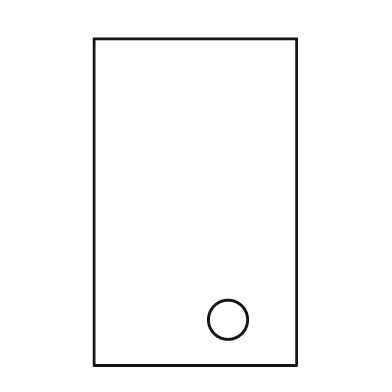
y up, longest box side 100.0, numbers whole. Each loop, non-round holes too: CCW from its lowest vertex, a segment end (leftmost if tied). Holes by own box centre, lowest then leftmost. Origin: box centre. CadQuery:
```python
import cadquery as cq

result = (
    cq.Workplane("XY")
    .moveTo(-31.0, -50.0)
    .lineTo(31.0, -50.0)
    .lineTo(31.0, 50.0)
    .lineTo(-31.0, 50.0)
    .close()
    .moveTo(10.0, -36.0)
    .circle(6.0)
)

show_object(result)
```